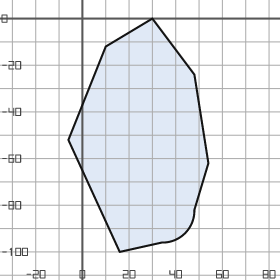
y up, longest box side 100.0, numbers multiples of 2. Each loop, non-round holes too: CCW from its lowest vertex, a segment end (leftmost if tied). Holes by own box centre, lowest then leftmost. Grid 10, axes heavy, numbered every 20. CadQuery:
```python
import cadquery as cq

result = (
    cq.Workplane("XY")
    .moveTo(16.0, -100.0)
    .lineTo(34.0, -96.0)
    .threePointArc((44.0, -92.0), (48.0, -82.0))
    .lineTo(54.0, -62.0)
    .lineTo(48.0, -24.0)
    .lineTo(30.0, 0.0)
    .lineTo(10.0, -12.0)
    .lineTo(-6.0, -52.0)
    .close()
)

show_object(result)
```